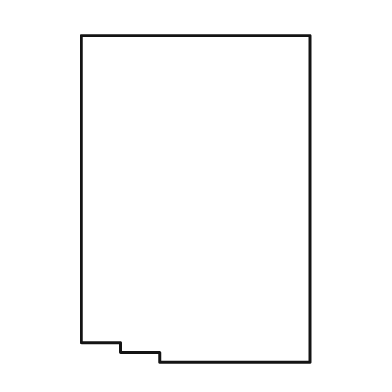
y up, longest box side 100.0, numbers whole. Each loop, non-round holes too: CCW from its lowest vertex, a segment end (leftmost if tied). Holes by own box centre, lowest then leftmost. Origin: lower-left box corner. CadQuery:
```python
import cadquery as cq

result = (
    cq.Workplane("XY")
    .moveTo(24.0, 0.0)
    .lineTo(70.0, 0.0)
    .lineTo(70.0, 100.0)
    .lineTo(0.0, 100.0)
    .lineTo(0.0, 6.0)
    .lineTo(12.0, 6.0)
    .lineTo(12.0, 3.0)
    .lineTo(24.0, 3.0)
    .close()
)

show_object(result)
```